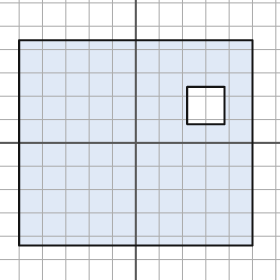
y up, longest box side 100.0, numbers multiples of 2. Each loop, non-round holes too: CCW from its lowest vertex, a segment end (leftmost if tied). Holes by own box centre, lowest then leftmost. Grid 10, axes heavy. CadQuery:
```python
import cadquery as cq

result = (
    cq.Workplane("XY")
    .moveTo(-50.0, -44.0)
    .lineTo(50.0, -44.0)
    .lineTo(50.0, 44.0)
    .lineTo(-50.0, 44.0)
    .close()
    .moveTo(22.0, 8.0)
    .lineTo(38.0, 8.0)
    .lineTo(38.0, 24.0)
    .lineTo(22.0, 24.0)
    .close()
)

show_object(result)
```